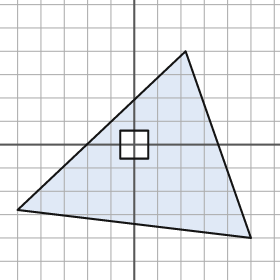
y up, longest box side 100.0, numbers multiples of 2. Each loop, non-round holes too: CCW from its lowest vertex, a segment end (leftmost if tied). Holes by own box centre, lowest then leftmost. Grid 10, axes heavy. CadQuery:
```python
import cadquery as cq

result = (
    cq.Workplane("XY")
    .moveTo(50.0, -40.0)
    .lineTo(22.0, 40.0)
    .lineTo(-50.0, -28.0)
    .close()
    .moveTo(-6.0, -6.0)
    .lineTo(6.0, -6.0)
    .lineTo(6.0, 6.0)
    .lineTo(-6.0, 6.0)
    .close()
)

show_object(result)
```